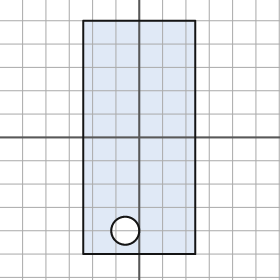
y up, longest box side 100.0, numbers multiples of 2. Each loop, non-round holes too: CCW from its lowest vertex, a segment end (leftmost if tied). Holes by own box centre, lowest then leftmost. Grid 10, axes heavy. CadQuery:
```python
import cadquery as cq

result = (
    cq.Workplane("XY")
    .moveTo(-24.0, -50.0)
    .lineTo(24.0, -50.0)
    .lineTo(24.0, 50.0)
    .lineTo(-24.0, 50.0)
    .close()
    .moveTo(-6.0, -40.0)
    .circle(6.0)
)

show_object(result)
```